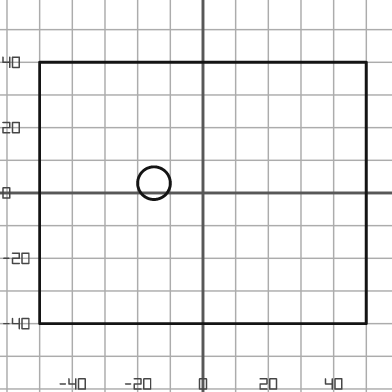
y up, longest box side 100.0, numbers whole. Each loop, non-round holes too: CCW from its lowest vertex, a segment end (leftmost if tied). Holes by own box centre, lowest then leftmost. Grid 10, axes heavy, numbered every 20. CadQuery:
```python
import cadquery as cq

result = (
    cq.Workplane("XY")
    .moveTo(-50.0, -40.0)
    .lineTo(50.0, -40.0)
    .lineTo(50.0, 40.0)
    .lineTo(-50.0, 40.0)
    .close()
    .moveTo(-15.0, 3.0)
    .circle(5.0)
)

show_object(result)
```